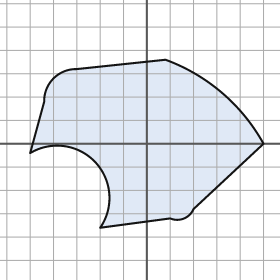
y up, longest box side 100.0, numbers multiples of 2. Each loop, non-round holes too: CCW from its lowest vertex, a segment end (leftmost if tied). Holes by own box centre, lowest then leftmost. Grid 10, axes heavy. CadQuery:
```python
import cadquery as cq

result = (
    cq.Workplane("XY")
    .moveTo(-20.0, -36.0)
    .lineTo(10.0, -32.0)
    .threePointArc((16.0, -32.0), (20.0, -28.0))
    .lineTo(50.0, 0.0)
    .threePointArc((32.0, 22.0), (8.0, 36.0))
    .lineTo(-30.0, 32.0)
    .threePointArc((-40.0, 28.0), (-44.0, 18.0))
    .lineTo(-50.0, -4.0)
    .threePointArc((-22.0, -8.0), (-20.0, -36.0))
    .close()
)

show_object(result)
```